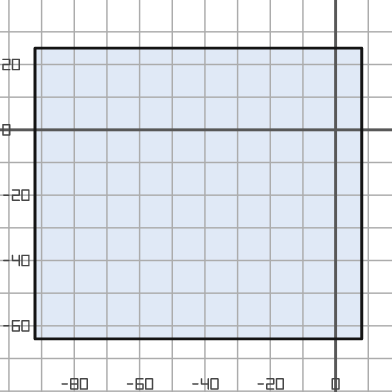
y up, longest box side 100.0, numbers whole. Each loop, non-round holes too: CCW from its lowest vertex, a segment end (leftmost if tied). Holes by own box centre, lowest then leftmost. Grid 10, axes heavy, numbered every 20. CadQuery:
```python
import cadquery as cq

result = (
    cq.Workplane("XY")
    .moveTo(-92.0, -64.0)
    .lineTo(8.0, -64.0)
    .lineTo(8.0, 25.0)
    .lineTo(-92.0, 25.0)
    .close()
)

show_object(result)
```